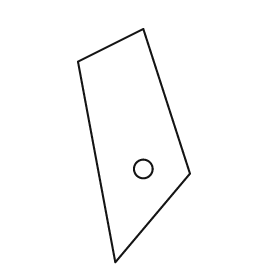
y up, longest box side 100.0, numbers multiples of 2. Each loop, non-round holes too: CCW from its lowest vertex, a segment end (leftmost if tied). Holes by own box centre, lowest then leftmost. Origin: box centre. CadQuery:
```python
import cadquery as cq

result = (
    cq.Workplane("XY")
    .moveTo(-8.0, -50.0)
    .lineTo(24.0, -12.0)
    .lineTo(4.0, 50.0)
    .lineTo(-24.0, 36.0)
    .close()
    .moveTo(4.0, -10.0)
    .circle(4.0)
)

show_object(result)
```